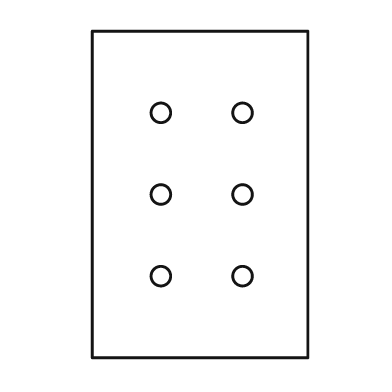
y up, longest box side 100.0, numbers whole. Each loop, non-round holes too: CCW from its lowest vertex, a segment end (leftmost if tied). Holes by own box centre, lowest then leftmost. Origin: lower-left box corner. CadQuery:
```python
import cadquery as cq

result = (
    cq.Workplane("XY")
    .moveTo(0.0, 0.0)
    .lineTo(66.0, 0.0)
    .lineTo(66.0, 100.0)
    .lineTo(0.0, 100.0)
    .close()
    .moveTo(21.0, 25.0)
    .circle(3.0)
    .moveTo(46.0, 25.0)
    .circle(3.0)
    .moveTo(21.0, 50.0)
    .circle(3.0)
    .moveTo(46.0, 50.0)
    .circle(3.0)
    .moveTo(21.0, 75.0)
    .circle(3.0)
    .moveTo(46.0, 75.0)
    .circle(3.0)
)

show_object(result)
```